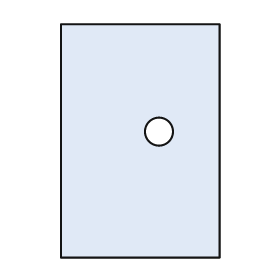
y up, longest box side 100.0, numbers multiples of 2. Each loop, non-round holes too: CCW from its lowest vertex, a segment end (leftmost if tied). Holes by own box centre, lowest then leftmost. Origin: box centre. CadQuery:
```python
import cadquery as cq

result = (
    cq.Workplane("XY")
    .moveTo(-34.0, -50.0)
    .lineTo(34.0, -50.0)
    .lineTo(34.0, 50.0)
    .lineTo(-34.0, 50.0)
    .close()
    .moveTo(8.0, 4.0)
    .circle(6.0)
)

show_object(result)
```